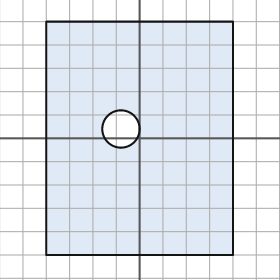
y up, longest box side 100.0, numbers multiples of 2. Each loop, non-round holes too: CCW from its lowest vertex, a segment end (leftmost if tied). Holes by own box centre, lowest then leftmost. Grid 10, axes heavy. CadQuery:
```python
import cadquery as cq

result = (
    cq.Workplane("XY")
    .moveTo(-40.0, -50.0)
    .lineTo(40.0, -50.0)
    .lineTo(40.0, 50.0)
    .lineTo(-40.0, 50.0)
    .close()
    .moveTo(-8.0, 4.0)
    .circle(8.0)
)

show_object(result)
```